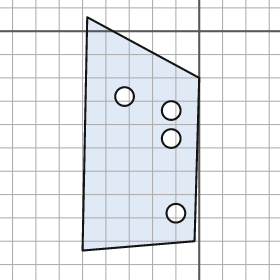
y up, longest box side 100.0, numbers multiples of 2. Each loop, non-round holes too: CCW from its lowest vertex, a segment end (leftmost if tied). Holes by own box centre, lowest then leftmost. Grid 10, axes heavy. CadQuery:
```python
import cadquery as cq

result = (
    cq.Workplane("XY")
    .moveTo(-50.0, -94.0)
    .lineTo(-2.0, -90.0)
    .lineTo(0.0, -20.0)
    .lineTo(-48.0, 6.0)
    .close()
    .moveTo(-10.0, -78.0)
    .circle(4.0)
    .moveTo(-12.0, -46.0)
    .circle(4.0)
    .moveTo(-12.0, -34.0)
    .circle(4.0)
    .moveTo(-32.0, -28.0)
    .circle(4.0)
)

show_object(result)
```